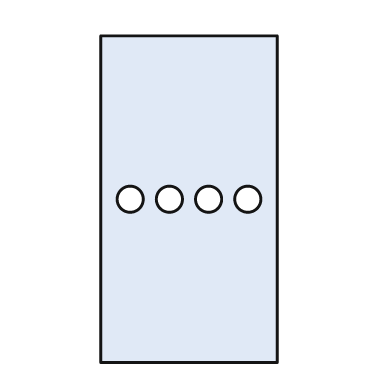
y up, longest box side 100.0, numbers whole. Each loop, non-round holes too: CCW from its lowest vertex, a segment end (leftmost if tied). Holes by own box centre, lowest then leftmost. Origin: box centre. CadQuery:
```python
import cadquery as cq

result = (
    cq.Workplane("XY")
    .moveTo(-27.0, -50.0)
    .lineTo(27.0, -50.0)
    .lineTo(27.0, 50.0)
    .lineTo(-27.0, 50.0)
    .close()
    .moveTo(-18.0, 0.0)
    .circle(4.0)
    .moveTo(-6.0, 0.0)
    .circle(4.0)
    .moveTo(6.0, 0.0)
    .circle(4.0)
    .moveTo(18.0, 0.0)
    .circle(4.0)
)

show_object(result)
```